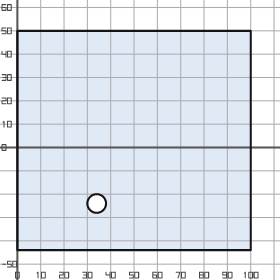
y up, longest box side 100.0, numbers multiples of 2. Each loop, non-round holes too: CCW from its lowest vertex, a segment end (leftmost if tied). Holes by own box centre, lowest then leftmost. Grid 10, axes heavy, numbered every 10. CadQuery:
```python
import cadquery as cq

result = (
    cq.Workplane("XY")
    .moveTo(0.0, -44.0)
    .lineTo(100.0, -44.0)
    .lineTo(100.0, 50.0)
    .lineTo(0.0, 50.0)
    .close()
    .moveTo(34.0, -24.0)
    .circle(4.0)
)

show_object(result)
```